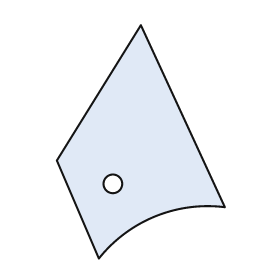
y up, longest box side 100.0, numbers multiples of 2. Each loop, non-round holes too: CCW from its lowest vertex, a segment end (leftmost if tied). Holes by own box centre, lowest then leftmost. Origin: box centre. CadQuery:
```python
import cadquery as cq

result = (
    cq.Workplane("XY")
    .moveTo(-18.0, -50.0)
    .threePointArc((6.0, -32.0), (36.0, -28.0))
    .lineTo(0.0, 50.0)
    .lineTo(-36.0, -8.0)
    .close()
    .moveTo(-12.0, -18.0)
    .circle(4.0)
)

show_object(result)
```